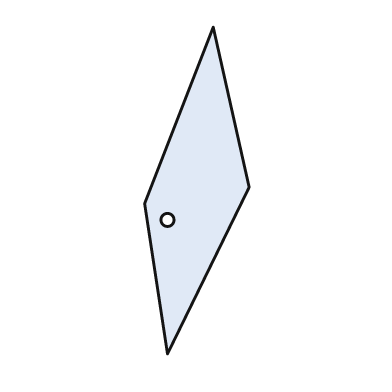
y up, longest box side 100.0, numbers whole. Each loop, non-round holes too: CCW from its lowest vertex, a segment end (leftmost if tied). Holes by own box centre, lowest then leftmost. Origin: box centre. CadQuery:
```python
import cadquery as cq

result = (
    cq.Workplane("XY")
    .moveTo(-9.0, -50.0)
    .lineTo(16.0, 1.0)
    .lineTo(5.0, 50.0)
    .lineTo(-16.0, -4.0)
    .close()
    .moveTo(-9.0, -9.0)
    .circle(2.0)
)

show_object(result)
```